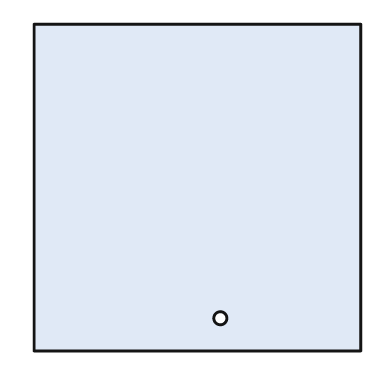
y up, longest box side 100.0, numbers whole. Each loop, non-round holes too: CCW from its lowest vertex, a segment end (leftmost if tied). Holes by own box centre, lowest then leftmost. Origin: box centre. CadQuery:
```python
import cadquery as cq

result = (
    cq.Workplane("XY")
    .moveTo(-50.0, -50.0)
    .lineTo(50.0, -50.0)
    .lineTo(50.0, 50.0)
    .lineTo(-50.0, 50.0)
    .close()
    .moveTo(7.0, -40.0)
    .circle(2.0)
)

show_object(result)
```